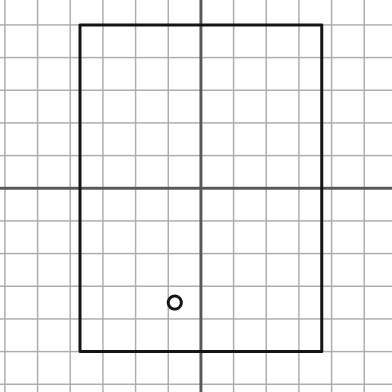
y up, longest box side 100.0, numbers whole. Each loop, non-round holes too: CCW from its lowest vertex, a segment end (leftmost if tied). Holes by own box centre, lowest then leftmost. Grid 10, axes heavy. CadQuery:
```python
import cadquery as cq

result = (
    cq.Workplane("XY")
    .moveTo(-37.0, -50.0)
    .lineTo(37.0, -50.0)
    .lineTo(37.0, 50.0)
    .lineTo(-37.0, 50.0)
    .close()
    .moveTo(-8.0, -35.0)
    .circle(2.0)
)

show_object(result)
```